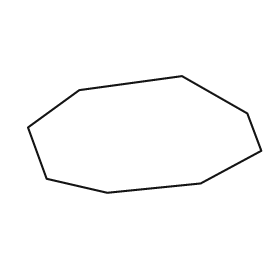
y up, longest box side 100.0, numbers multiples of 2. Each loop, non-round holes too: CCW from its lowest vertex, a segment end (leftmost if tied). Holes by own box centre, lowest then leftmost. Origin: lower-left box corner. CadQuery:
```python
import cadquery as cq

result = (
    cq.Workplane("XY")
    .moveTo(34.0, 0.0)
    .lineTo(74.0, 4.0)
    .lineTo(100.0, 18.0)
    .lineTo(94.0, 34.0)
    .lineTo(66.0, 50.0)
    .lineTo(22.0, 44.0)
    .lineTo(0.0, 28.0)
    .lineTo(8.0, 6.0)
    .close()
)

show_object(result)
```